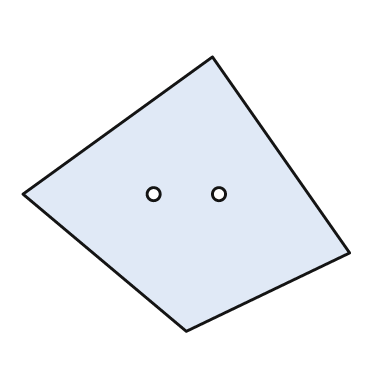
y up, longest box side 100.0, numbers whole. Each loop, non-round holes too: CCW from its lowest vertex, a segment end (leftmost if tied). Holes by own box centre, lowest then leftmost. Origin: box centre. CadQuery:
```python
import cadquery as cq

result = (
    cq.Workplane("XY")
    .moveTo(0.0, -42.0)
    .lineTo(50.0, -18.0)
    .lineTo(8.0, 42.0)
    .lineTo(-50.0, 0.0)
    .close()
    .moveTo(-10.0, 0.0)
    .circle(2.0)
    .moveTo(10.0, 0.0)
    .circle(2.0)
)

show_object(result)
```